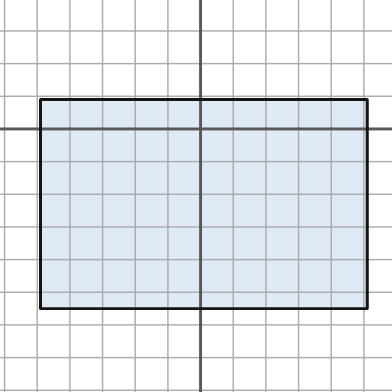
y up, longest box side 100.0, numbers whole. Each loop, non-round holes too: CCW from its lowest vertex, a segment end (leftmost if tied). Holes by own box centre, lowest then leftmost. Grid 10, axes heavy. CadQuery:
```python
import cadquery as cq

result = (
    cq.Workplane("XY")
    .moveTo(-49.0, -55.0)
    .lineTo(51.0, -55.0)
    .lineTo(51.0, 9.0)
    .lineTo(-49.0, 9.0)
    .close()
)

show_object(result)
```